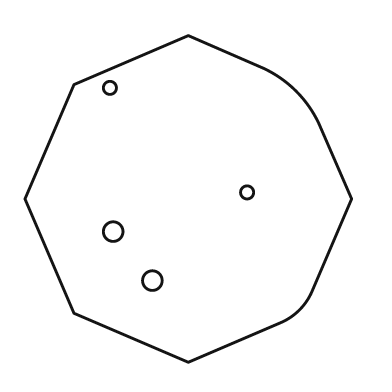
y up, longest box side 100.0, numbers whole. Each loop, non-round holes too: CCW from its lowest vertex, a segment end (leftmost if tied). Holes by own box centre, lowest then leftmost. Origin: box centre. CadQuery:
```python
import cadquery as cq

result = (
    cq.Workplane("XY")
    .moveTo(0.0, -50.0)
    .lineTo(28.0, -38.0)
    .threePointArc((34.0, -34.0), (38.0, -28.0))
    .lineTo(50.0, 0.0)
    .lineTo(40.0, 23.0)
    .threePointArc((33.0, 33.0), (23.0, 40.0))
    .lineTo(0.0, 50.0)
    .lineTo(-35.0, 35.0)
    .lineTo(-50.0, 0.0)
    .lineTo(-35.0, -35.0)
    .close()
    .moveTo(-11.0, -25.0)
    .circle(3.0)
    .moveTo(-23.0, -10.0)
    .circle(3.0)
    .moveTo(18.0, 2.0)
    .circle(2.0)
    .moveTo(-24.0, 34.0)
    .circle(2.0)
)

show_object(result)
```